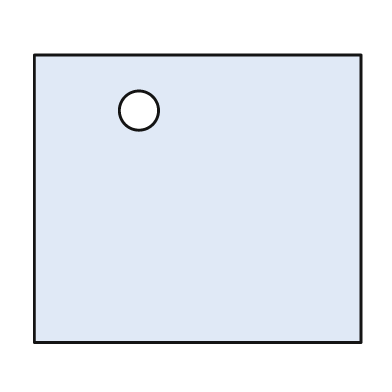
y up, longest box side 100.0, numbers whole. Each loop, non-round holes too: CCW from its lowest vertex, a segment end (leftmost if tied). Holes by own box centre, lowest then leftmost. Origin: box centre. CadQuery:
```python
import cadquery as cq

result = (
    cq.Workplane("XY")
    .moveTo(-50.0, -44.0)
    .lineTo(50.0, -44.0)
    .lineTo(50.0, 44.0)
    .lineTo(-50.0, 44.0)
    .close()
    .moveTo(-18.0, 27.0)
    .circle(6.0)
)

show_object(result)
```